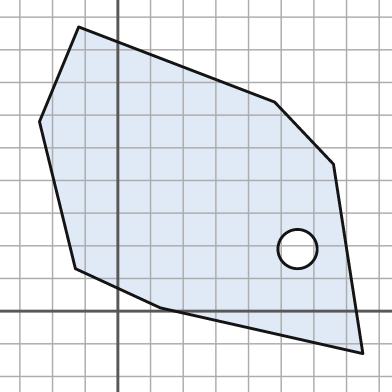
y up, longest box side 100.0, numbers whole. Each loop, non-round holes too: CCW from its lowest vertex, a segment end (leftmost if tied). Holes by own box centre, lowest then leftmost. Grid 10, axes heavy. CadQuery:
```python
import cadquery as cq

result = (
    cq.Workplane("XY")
    .moveTo(75.0, -13.0)
    .lineTo(66.0, 45.0)
    .lineTo(48.0, 64.0)
    .lineTo(-12.0, 87.0)
    .lineTo(-24.0, 58.0)
    .lineTo(-13.0, 13.0)
    .lineTo(13.0, 1.0)
    .close()
    .moveTo(55.0, 19.0)
    .circle(6.0)
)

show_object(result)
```